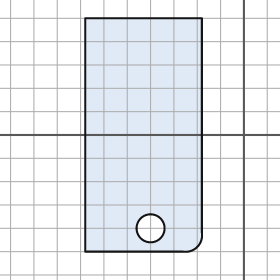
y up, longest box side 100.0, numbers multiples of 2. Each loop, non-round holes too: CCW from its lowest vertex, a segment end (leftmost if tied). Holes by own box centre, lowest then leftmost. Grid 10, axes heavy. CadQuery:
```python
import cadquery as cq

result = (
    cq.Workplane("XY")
    .moveTo(-68.0, -50.0)
    .lineTo(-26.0, -50.0)
    .threePointArc((-20.0, -48.0), (-18.0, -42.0))
    .lineTo(-18.0, 50.0)
    .lineTo(-68.0, 50.0)
    .close()
    .moveTo(-40.0, -40.0)
    .circle(6.0)
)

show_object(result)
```